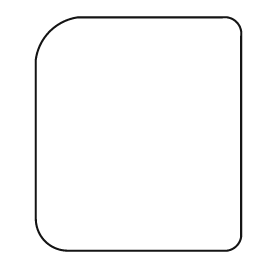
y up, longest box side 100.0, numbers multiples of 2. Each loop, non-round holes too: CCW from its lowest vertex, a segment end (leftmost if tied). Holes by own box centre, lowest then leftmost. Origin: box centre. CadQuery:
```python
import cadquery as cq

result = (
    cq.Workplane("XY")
    .moveTo(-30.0, -50.0)
    .lineTo(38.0, -50.0)
    .threePointArc((42.0, -48.0), (44.0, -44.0))
    .lineTo(44.0, 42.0)
    .threePointArc((42.0, 48.0), (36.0, 50.0))
    .lineTo(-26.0, 50.0)
    .threePointArc((-38.0, 44.0), (-44.0, 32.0))
    .lineTo(-44.0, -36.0)
    .threePointArc((-40.0, -46.0), (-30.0, -50.0))
    .close()
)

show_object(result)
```